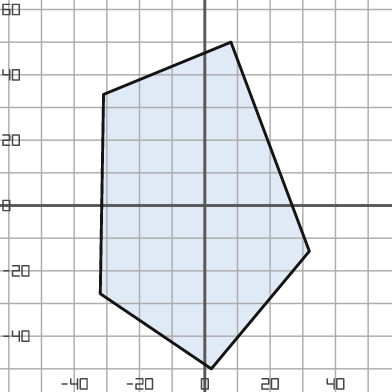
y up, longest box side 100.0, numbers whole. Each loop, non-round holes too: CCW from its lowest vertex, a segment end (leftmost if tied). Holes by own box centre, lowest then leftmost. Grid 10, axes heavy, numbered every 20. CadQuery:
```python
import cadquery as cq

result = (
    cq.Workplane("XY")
    .moveTo(2.0, -50.0)
    .lineTo(32.0, -14.0)
    .lineTo(8.0, 50.0)
    .lineTo(-31.0, 34.0)
    .lineTo(-32.0, -27.0)
    .close()
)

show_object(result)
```